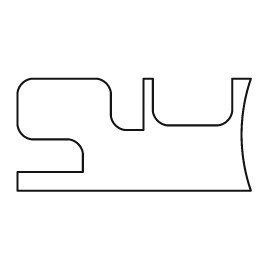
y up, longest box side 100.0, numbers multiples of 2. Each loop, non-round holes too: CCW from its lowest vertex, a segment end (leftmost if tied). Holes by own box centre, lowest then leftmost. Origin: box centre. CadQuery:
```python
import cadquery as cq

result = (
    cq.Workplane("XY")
    .moveTo(-50.0, -24.0)
    .lineTo(50.0, -24.0)
    .threePointArc((46.0, 0.0), (50.0, 24.0))
    .lineTo(42.0, 24.0)
    .lineTo(42.0, 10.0)
    .threePointArc((40.0, 6.0), (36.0, 4.0))
    .lineTo(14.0, 4.0)
    .threePointArc((10.0, 6.0), (8.0, 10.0))
    .lineTo(8.0, 24.0)
    .lineTo(4.0, 24.0)
    .lineTo(4.0, 2.0)
    .lineTo(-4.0, 2.0)
    .threePointArc((-8.0, 4.0), (-10.0, 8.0))
    .lineTo(-10.0, 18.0)
    .threePointArc((-12.0, 22.0), (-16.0, 24.0))
    .lineTo(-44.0, 24.0)
    .threePointArc((-48.0, 22.0), (-50.0, 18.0))
    .lineTo(-50.0, 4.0)
    .threePointArc((-48.0, 0.0), (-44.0, -2.0))
    .lineTo(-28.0, -2.0)
    .threePointArc((-24.0, -4.0), (-22.0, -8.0))
    .lineTo(-22.0, -16.0)
    .lineTo(-50.0, -16.0)
    .close()
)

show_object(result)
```